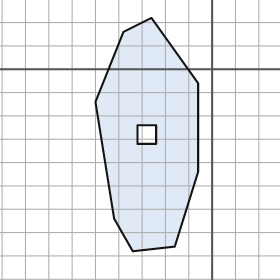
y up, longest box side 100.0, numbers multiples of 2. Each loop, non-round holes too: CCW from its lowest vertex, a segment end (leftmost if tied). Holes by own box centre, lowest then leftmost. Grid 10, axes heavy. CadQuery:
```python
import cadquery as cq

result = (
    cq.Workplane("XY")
    .moveTo(-34.0, -78.0)
    .lineTo(-16.0, -76.0)
    .lineTo(-6.0, -44.0)
    .lineTo(-6.0, -6.0)
    .lineTo(-26.0, 22.0)
    .lineTo(-38.0, 16.0)
    .lineTo(-50.0, -14.0)
    .lineTo(-42.0, -64.0)
    .close()
    .moveTo(-32.0, -32.0)
    .lineTo(-24.0, -32.0)
    .lineTo(-24.0, -24.0)
    .lineTo(-32.0, -24.0)
    .close()
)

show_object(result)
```